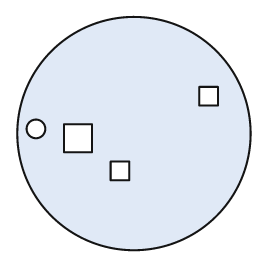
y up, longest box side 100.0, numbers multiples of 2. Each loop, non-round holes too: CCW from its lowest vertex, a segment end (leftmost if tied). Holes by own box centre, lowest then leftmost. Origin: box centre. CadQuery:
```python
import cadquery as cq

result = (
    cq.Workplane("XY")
    .moveTo(0.0, 0.0)
    .circle(50.0)
    .moveTo(-10.0, -20.0)
    .lineTo(-2.0, -20.0)
    .lineTo(-2.0, -12.0)
    .lineTo(-10.0, -12.0)
    .close()
    .moveTo(-30.0, -8.0)
    .lineTo(-18.0, -8.0)
    .lineTo(-18.0, 4.0)
    .lineTo(-30.0, 4.0)
    .close()
    .moveTo(-42.0, 2.0)
    .circle(4.0)
    .moveTo(28.0, 12.0)
    .lineTo(36.0, 12.0)
    .lineTo(36.0, 20.0)
    .lineTo(28.0, 20.0)
    .close()
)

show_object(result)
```